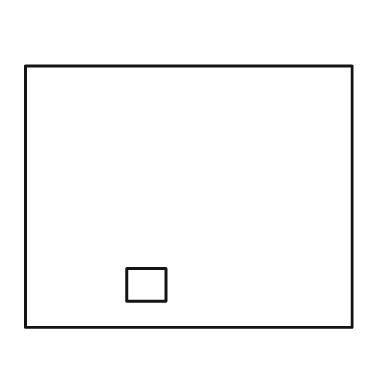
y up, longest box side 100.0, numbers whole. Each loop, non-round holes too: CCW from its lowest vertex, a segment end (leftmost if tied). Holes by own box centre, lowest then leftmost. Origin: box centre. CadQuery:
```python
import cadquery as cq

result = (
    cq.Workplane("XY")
    .moveTo(-50.0, -40.0)
    .lineTo(50.0, -40.0)
    .lineTo(50.0, 40.0)
    .lineTo(-50.0, 40.0)
    .close()
    .moveTo(-19.0, -32.0)
    .lineTo(-7.0, -32.0)
    .lineTo(-7.0, -22.0)
    .lineTo(-19.0, -22.0)
    .close()
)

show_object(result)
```